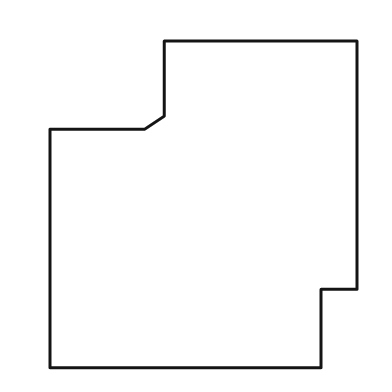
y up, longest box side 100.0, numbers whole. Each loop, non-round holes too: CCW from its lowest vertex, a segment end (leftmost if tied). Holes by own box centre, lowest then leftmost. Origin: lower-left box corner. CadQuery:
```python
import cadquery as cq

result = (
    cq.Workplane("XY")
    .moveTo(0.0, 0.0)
    .lineTo(83.0, 0.0)
    .lineTo(83.0, 24.0)
    .lineTo(94.0, 24.0)
    .lineTo(94.0, 100.0)
    .lineTo(35.0, 100.0)
    .lineTo(35.0, 77.0)
    .lineTo(29.0, 73.0)
    .lineTo(0.0, 73.0)
    .close()
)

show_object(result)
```